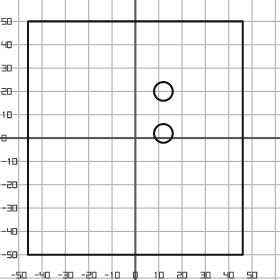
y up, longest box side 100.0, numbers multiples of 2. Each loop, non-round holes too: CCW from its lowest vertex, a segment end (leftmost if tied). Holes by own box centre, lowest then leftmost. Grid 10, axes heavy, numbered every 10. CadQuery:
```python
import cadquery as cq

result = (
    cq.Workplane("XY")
    .moveTo(-46.0, -50.0)
    .lineTo(46.0, -50.0)
    .lineTo(46.0, 50.0)
    .lineTo(-46.0, 50.0)
    .close()
    .moveTo(12.0, 2.0)
    .circle(4.0)
    .moveTo(12.0, 20.0)
    .circle(4.0)
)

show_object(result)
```